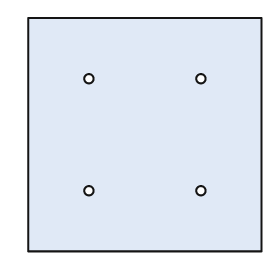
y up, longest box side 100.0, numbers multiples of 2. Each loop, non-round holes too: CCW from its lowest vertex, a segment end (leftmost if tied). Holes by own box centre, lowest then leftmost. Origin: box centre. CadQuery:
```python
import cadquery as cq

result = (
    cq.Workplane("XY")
    .moveTo(-50.0, -50.0)
    .lineTo(50.0, -50.0)
    .lineTo(50.0, 50.0)
    .lineTo(-50.0, 50.0)
    .close()
    .moveTo(-24.0, -24.0)
    .circle(2.0)
    .moveTo(24.0, -24.0)
    .circle(2.0)
    .moveTo(-24.0, 24.0)
    .circle(2.0)
    .moveTo(24.0, 24.0)
    .circle(2.0)
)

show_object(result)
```